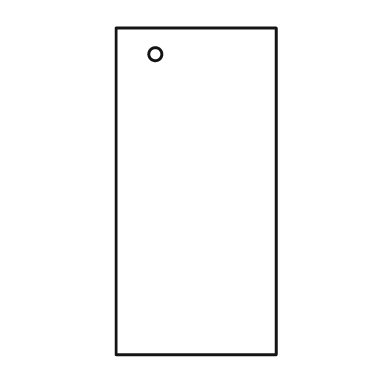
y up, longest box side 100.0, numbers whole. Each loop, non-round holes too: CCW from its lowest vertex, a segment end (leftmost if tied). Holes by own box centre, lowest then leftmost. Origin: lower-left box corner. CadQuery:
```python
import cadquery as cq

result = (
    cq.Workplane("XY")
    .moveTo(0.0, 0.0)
    .lineTo(49.0, 0.0)
    .lineTo(49.0, 100.0)
    .lineTo(0.0, 100.0)
    .close()
    .moveTo(12.0, 92.0)
    .circle(2.0)
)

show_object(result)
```